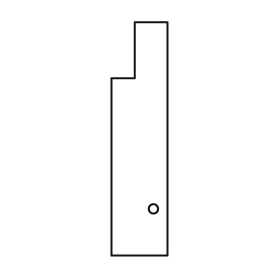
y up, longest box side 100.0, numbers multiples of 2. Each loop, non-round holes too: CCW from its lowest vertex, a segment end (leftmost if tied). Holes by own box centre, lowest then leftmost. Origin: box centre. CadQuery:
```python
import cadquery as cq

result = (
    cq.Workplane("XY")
    .moveTo(-12.0, -50.0)
    .lineTo(12.0, -50.0)
    .lineTo(12.0, 50.0)
    .lineTo(-2.0, 50.0)
    .lineTo(-2.0, 26.0)
    .lineTo(-12.0, 26.0)
    .close()
    .moveTo(6.0, -30.0)
    .circle(2.0)
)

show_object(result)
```